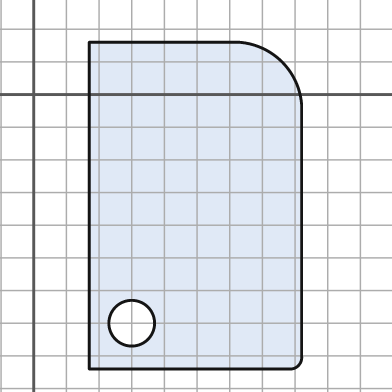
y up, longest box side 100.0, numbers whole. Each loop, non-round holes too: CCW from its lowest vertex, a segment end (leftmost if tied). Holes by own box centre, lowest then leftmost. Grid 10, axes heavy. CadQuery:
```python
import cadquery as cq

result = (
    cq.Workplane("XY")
    .moveTo(17.0, -84.0)
    .lineTo(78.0, -84.0)
    .threePointArc((81.0, -83.0), (82.0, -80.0))
    .lineTo(82.0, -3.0)
    .threePointArc((76.0, 10.0), (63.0, 16.0))
    .lineTo(17.0, 16.0)
    .close()
    .moveTo(30.0, -70.0)
    .circle(7.0)
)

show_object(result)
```